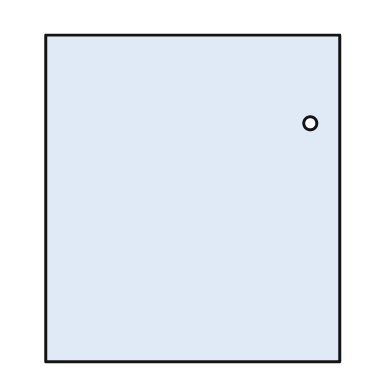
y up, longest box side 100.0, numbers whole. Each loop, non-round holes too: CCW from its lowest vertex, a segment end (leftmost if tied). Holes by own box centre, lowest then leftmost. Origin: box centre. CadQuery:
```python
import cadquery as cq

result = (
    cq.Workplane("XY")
    .moveTo(-45.0, -50.0)
    .lineTo(45.0, -50.0)
    .lineTo(45.0, 50.0)
    .lineTo(-45.0, 50.0)
    .close()
    .moveTo(36.0, 23.0)
    .circle(2.0)
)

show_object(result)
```